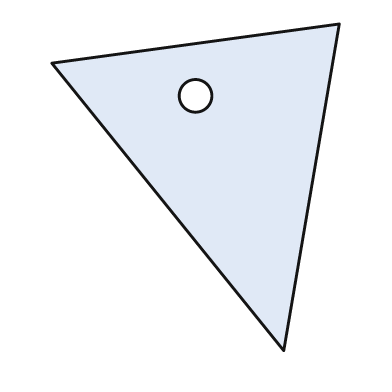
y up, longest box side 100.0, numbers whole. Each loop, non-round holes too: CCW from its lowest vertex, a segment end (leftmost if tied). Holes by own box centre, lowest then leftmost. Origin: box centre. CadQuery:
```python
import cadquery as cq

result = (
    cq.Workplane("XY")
    .moveTo(27.0, -50.0)
    .lineTo(44.0, 50.0)
    .lineTo(-44.0, 38.0)
    .close()
    .moveTo(0.0, 28.0)
    .circle(5.0)
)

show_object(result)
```